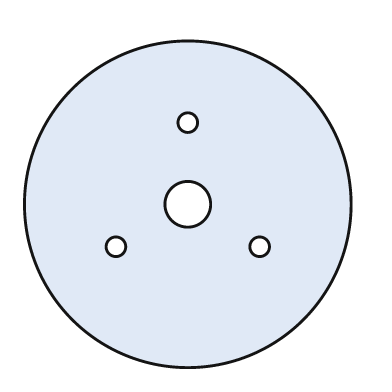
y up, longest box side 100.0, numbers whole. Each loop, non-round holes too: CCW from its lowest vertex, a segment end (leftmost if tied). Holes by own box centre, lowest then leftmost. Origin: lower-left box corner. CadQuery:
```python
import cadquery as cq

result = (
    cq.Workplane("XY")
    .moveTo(50.0, 50.0)
    .circle(50.0)
    .moveTo(28.0, 37.0)
    .circle(3.0)
    .moveTo(72.0, 37.0)
    .circle(3.0)
    .moveTo(50.0, 50.0)
    .circle(7.0)
    .moveTo(50.0, 75.0)
    .circle(3.0)
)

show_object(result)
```